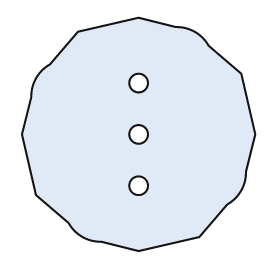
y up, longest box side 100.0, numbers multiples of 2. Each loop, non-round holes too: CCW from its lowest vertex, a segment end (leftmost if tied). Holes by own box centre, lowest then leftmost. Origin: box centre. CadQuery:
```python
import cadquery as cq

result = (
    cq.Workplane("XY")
    .moveTo(0.0, -50.0)
    .lineTo(26.0, -44.0)
    .lineTo(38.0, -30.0)
    .threePointArc((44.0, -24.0), (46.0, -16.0))
    .lineTo(50.0, 0.0)
    .lineTo(44.0, 26.0)
    .lineTo(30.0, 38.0)
    .threePointArc((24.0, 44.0), (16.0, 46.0))
    .lineTo(0.0, 50.0)
    .lineTo(-26.0, 44.0)
    .lineTo(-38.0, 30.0)
    .threePointArc((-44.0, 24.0), (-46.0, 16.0))
    .lineTo(-50.0, 0.0)
    .lineTo(-44.0, -26.0)
    .lineTo(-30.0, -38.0)
    .threePointArc((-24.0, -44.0), (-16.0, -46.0))
    .close()
    .moveTo(0.0, -22.0)
    .circle(4.0)
    .moveTo(0.0, 0.0)
    .circle(4.0)
    .moveTo(0.0, 22.0)
    .circle(4.0)
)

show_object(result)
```